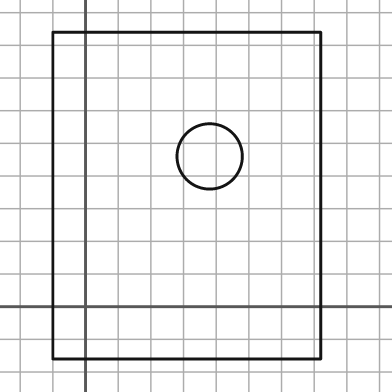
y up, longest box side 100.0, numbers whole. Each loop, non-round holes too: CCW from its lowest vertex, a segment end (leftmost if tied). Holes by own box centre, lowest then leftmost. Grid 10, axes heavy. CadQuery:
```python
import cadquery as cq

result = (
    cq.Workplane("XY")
    .moveTo(-10.0, -16.0)
    .lineTo(72.0, -16.0)
    .lineTo(72.0, 84.0)
    .lineTo(-10.0, 84.0)
    .close()
    .moveTo(38.0, 46.0)
    .circle(10.0)
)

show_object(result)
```